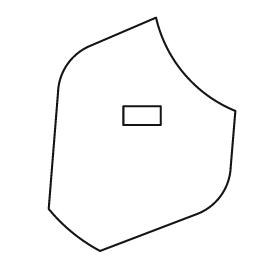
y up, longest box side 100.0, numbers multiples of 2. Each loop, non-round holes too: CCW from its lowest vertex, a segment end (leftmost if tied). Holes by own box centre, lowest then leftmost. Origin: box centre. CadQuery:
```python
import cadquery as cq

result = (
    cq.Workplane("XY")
    .moveTo(-18.0, -50.0)
    .lineTo(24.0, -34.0)
    .threePointArc((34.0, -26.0), (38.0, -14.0))
    .lineTo(40.0, 10.0)
    .threePointArc((18.0, 26.0), (6.0, 50.0))
    .lineTo(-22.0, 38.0)
    .threePointArc((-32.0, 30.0), (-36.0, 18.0))
    .lineTo(-40.0, -32.0)
    .threePointArc((-30.0, -42.0), (-18.0, -50.0))
    .close()
    .moveTo(-8.0, 4.0)
    .lineTo(8.0, 4.0)
    .lineTo(8.0, 12.0)
    .lineTo(-8.0, 12.0)
    .close()
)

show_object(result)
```